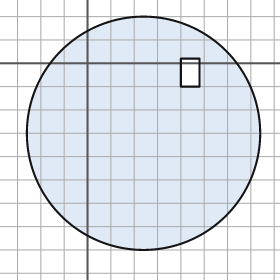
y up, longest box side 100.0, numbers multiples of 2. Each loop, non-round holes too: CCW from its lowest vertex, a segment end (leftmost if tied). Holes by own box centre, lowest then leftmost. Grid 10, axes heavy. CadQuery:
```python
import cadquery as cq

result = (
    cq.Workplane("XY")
    .moveTo(24.0, -30.0)
    .circle(50.0)
    .moveTo(40.0, -10.0)
    .lineTo(48.0, -10.0)
    .lineTo(48.0, 2.0)
    .lineTo(40.0, 2.0)
    .close()
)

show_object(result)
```